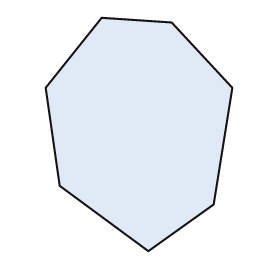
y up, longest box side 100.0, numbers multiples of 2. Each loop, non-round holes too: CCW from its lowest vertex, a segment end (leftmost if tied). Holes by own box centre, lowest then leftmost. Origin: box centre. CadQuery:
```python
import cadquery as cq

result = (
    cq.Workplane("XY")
    .moveTo(4.0, -50.0)
    .lineTo(32.0, -30.0)
    .lineTo(40.0, 20.0)
    .lineTo(14.0, 48.0)
    .lineTo(-16.0, 50.0)
    .lineTo(-40.0, 20.0)
    .lineTo(-34.0, -22.0)
    .close()
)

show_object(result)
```